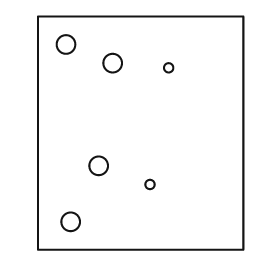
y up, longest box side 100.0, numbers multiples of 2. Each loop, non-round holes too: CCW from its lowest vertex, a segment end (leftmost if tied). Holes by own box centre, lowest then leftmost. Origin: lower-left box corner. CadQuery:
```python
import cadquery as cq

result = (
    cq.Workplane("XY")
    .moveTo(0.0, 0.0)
    .lineTo(88.0, 0.0)
    .lineTo(88.0, 100.0)
    .lineTo(0.0, 100.0)
    .close()
    .moveTo(14.0, 12.0)
    .circle(4.0)
    .moveTo(48.0, 28.0)
    .circle(2.0)
    .moveTo(26.0, 36.0)
    .circle(4.0)
    .moveTo(56.0, 78.0)
    .circle(2.0)
    .moveTo(32.0, 80.0)
    .circle(4.0)
    .moveTo(12.0, 88.0)
    .circle(4.0)
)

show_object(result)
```